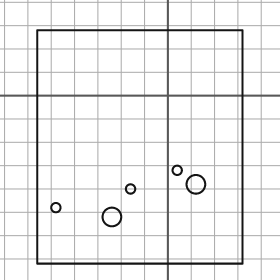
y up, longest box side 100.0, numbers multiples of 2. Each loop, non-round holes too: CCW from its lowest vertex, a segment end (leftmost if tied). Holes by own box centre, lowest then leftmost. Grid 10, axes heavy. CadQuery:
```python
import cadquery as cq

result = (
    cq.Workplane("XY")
    .moveTo(-56.0, -72.0)
    .lineTo(32.0, -72.0)
    .lineTo(32.0, 28.0)
    .lineTo(-56.0, 28.0)
    .close()
    .moveTo(-24.0, -52.0)
    .circle(4.0)
    .moveTo(-48.0, -48.0)
    .circle(2.0)
    .moveTo(-16.0, -40.0)
    .circle(2.0)
    .moveTo(12.0, -38.0)
    .circle(4.0)
    .moveTo(4.0, -32.0)
    .circle(2.0)
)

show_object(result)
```